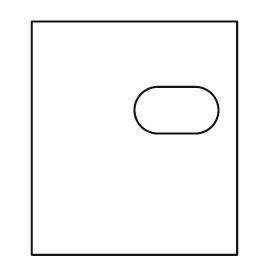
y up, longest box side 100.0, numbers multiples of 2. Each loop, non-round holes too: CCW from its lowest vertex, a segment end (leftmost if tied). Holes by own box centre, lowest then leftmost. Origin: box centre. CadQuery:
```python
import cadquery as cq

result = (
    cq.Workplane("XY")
    .moveTo(-44.0, -50.0)
    .lineTo(44.0, -50.0)
    .lineTo(44.0, 50.0)
    .lineTo(-44.0, 50.0)
    .close()
    .moveTo(10.0, 2.0)
    .lineTo(26.0, 2.0)
    .threePointArc((36.0, 12.0), (26.0, 22.0))
    .lineTo(10.0, 22.0)
    .threePointArc((0.0, 12.0), (10.0, 2.0))
    .close()
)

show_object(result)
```